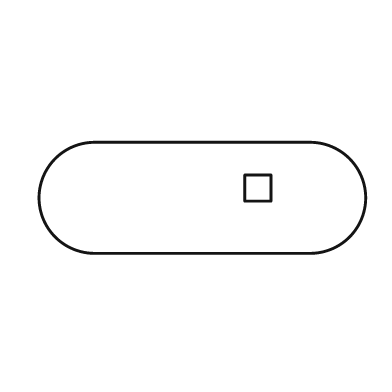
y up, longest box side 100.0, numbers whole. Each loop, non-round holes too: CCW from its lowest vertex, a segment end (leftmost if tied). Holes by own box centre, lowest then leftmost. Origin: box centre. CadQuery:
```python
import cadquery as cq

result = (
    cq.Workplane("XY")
    .moveTo(-33.0, -17.0)
    .lineTo(33.0, -17.0)
    .threePointArc((50.0, 0.0), (33.0, 17.0))
    .lineTo(-33.0, 17.0)
    .threePointArc((-50.0, 0.0), (-33.0, -17.0))
    .close()
    .moveTo(13.0, -1.0)
    .lineTo(21.0, -1.0)
    .lineTo(21.0, 7.0)
    .lineTo(13.0, 7.0)
    .close()
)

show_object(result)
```